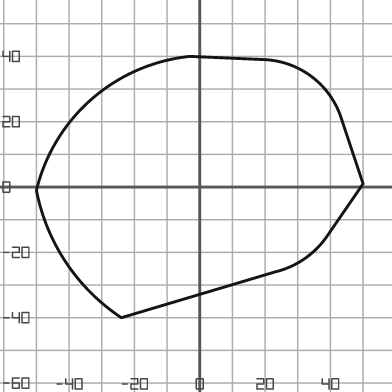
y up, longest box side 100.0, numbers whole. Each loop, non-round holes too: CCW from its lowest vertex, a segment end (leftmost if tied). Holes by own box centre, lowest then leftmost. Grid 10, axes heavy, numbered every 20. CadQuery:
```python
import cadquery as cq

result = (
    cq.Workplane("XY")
    .moveTo(-24.0, -40.0)
    .lineTo(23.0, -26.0)
    .threePointArc((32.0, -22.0), (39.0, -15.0))
    .lineTo(50.0, 1.0)
    .lineTo(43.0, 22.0)
    .threePointArc((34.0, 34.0), (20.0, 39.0))
    .lineTo(-3.0, 40.0)
    .threePointArc((-33.0, 27.0), (-50.0, -1.0))
    .threePointArc((-41.0, -23.0), (-24.0, -40.0))
    .close()
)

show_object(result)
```